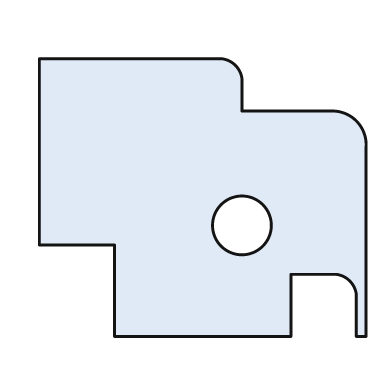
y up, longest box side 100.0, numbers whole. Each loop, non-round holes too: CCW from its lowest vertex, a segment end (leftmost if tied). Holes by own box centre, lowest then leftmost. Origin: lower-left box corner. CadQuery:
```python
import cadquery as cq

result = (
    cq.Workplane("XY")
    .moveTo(23.0, 0.0)
    .lineTo(77.0, 0.0)
    .lineTo(77.0, 19.0)
    .lineTo(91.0, 19.0)
    .threePointArc((95.0, 17.0), (97.0, 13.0))
    .lineTo(97.0, 0.0)
    .lineTo(100.0, 0.0)
    .lineTo(100.0, 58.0)
    .threePointArc((97.0, 66.0), (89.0, 69.0))
    .lineTo(62.0, 69.0)
    .lineTo(62.0, 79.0)
    .threePointArc((60.0, 83.0), (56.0, 85.0))
    .lineTo(0.0, 85.0)
    .lineTo(0.0, 28.0)
    .lineTo(23.0, 28.0)
    .close()
    .moveTo(62.0, 34.0)
    .circle(9.0)
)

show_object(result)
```